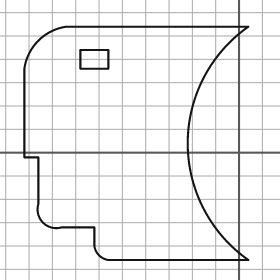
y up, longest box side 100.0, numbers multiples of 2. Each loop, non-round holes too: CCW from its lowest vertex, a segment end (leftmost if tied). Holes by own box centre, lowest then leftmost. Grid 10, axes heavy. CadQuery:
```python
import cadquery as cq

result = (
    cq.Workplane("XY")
    .moveTo(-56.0, -46.0)
    .lineTo(4.0, -46.0)
    .threePointArc((-22.0, 4.0), (4.0, 54.0))
    .lineTo(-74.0, 54.0)
    .threePointArc((-86.0, 48.0), (-92.0, 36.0))
    .lineTo(-92.0, -2.0)
    .lineTo(-86.0, -2.0)
    .lineTo(-86.0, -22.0)
    .threePointArc((-84.0, -30.0), (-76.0, -32.0))
    .lineTo(-62.0, -32.0)
    .lineTo(-62.0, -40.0)
    .threePointArc((-60.0, -44.0), (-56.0, -46.0))
    .close()
    .moveTo(-68.0, 36.0)
    .lineTo(-56.0, 36.0)
    .lineTo(-56.0, 44.0)
    .lineTo(-68.0, 44.0)
    .close()
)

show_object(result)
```